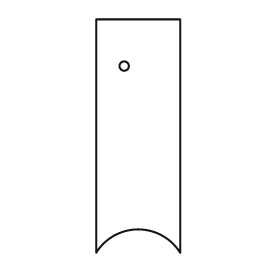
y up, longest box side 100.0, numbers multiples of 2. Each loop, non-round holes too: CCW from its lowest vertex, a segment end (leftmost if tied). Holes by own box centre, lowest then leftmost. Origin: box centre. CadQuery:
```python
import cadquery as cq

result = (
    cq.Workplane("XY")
    .moveTo(-18.0, -50.0)
    .threePointArc((0.0, -40.0), (18.0, -50.0))
    .lineTo(18.0, 50.0)
    .lineTo(-18.0, 50.0)
    .close()
    .moveTo(-6.0, 30.0)
    .circle(2.0)
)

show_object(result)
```